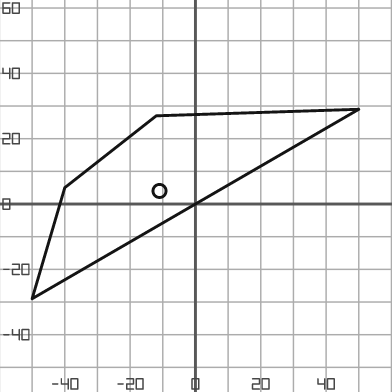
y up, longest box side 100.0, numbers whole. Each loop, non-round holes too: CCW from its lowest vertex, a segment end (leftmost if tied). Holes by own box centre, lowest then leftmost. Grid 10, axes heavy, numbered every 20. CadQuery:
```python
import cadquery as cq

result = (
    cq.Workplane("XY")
    .moveTo(-50.0, -29.0)
    .lineTo(50.0, 29.0)
    .lineTo(-12.0, 27.0)
    .lineTo(-40.0, 5.0)
    .close()
    .moveTo(-11.0, 4.0)
    .circle(2.0)
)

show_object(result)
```